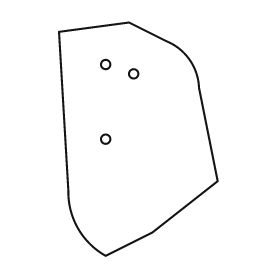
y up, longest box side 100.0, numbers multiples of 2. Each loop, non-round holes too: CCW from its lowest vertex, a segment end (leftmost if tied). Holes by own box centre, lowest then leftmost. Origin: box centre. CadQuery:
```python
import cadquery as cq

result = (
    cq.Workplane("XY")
    .moveTo(-14.0, -50.0)
    .lineTo(6.0, -40.0)
    .lineTo(34.0, -18.0)
    .lineTo(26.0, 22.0)
    .threePointArc((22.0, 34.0), (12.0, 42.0))
    .lineTo(-4.0, 50.0)
    .lineTo(-34.0, 46.0)
    .lineTo(-30.0, -22.0)
    .threePointArc((-26.0, -38.0), (-14.0, -50.0))
    .close()
    .moveTo(-14.0, 0.0)
    .circle(2.0)
    .moveTo(-2.0, 28.0)
    .circle(2.0)
    .moveTo(-14.0, 32.0)
    .circle(2.0)
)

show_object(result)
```